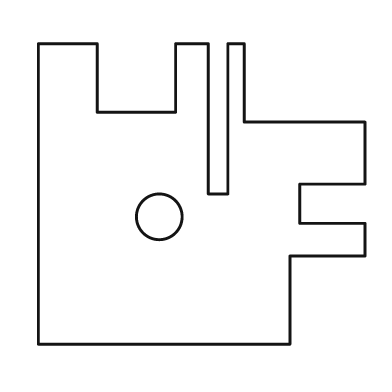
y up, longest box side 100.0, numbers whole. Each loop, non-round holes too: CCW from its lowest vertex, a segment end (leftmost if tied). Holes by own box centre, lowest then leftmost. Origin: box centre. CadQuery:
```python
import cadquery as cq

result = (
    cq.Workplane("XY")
    .moveTo(-50.0, -46.0)
    .lineTo(27.0, -46.0)
    .lineTo(27.0, -19.0)
    .lineTo(50.0, -19.0)
    .lineTo(50.0, -9.0)
    .lineTo(30.0, -9.0)
    .lineTo(30.0, 3.0)
    .lineTo(50.0, 3.0)
    .lineTo(50.0, 22.0)
    .lineTo(13.0, 22.0)
    .lineTo(13.0, 46.0)
    .lineTo(8.0, 46.0)
    .lineTo(8.0, 0.0)
    .lineTo(2.0, 0.0)
    .lineTo(2.0, 46.0)
    .lineTo(-8.0, 46.0)
    .lineTo(-8.0, 25.0)
    .lineTo(-32.0, 25.0)
    .lineTo(-32.0, 46.0)
    .lineTo(-50.0, 46.0)
    .close()
    .moveTo(-13.0, -7.0)
    .circle(7.0)
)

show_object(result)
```